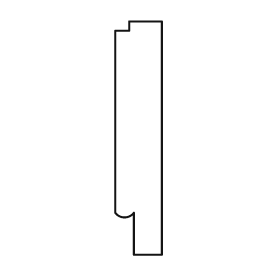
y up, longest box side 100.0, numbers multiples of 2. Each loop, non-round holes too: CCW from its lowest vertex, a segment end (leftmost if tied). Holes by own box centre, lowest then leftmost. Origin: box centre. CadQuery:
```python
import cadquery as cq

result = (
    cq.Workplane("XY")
    .moveTo(-2.0, -50.0)
    .lineTo(10.0, -50.0)
    .lineTo(10.0, 50.0)
    .lineTo(-4.0, 50.0)
    .lineTo(-4.0, 46.0)
    .lineTo(-10.0, 46.0)
    .lineTo(-10.0, -32.0)
    .threePointArc((-6.0, -34.0), (-2.0, -32.0))
    .close()
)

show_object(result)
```